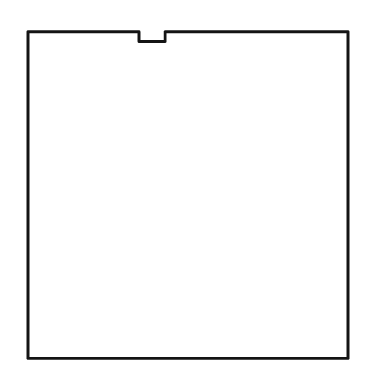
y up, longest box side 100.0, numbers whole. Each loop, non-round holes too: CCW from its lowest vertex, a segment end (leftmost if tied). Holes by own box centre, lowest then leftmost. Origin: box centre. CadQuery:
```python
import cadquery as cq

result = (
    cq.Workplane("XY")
    .moveTo(-49.0, -50.0)
    .lineTo(49.0, -50.0)
    .lineTo(49.0, 50.0)
    .lineTo(-7.0, 50.0)
    .lineTo(-7.0, 47.0)
    .lineTo(-15.0, 47.0)
    .lineTo(-15.0, 50.0)
    .lineTo(-49.0, 50.0)
    .close()
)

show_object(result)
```